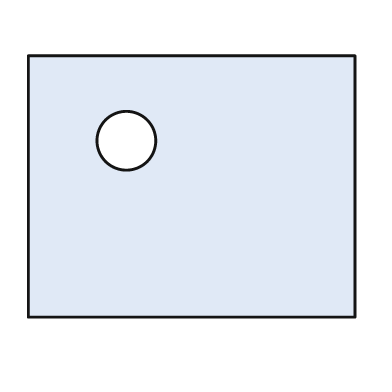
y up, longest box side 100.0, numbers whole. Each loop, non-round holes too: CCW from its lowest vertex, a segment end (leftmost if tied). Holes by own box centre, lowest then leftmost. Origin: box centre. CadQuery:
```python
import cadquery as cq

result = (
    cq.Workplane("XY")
    .moveTo(-50.0, -40.0)
    .lineTo(50.0, -40.0)
    .lineTo(50.0, 40.0)
    .lineTo(-50.0, 40.0)
    .close()
    .moveTo(-20.0, 14.0)
    .circle(9.0)
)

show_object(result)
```